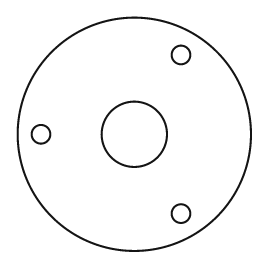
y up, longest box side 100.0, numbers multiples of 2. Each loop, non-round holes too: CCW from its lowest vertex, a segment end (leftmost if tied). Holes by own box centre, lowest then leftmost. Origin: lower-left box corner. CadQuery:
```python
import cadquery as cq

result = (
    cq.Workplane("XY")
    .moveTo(50.0, 50.0)
    .circle(50.0)
    .moveTo(70.0, 16.0)
    .circle(4.0)
    .moveTo(10.0, 50.0)
    .circle(4.0)
    .moveTo(50.0, 50.0)
    .circle(14.0)
    .moveTo(70.0, 84.0)
    .circle(4.0)
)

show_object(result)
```